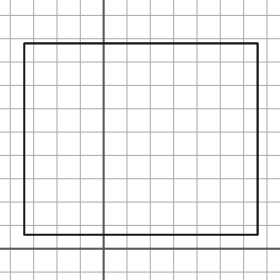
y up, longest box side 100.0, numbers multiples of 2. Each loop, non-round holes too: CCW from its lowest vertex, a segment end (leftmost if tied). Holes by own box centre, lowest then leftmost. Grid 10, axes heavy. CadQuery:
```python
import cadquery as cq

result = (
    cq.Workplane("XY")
    .moveTo(-34.0, 6.0)
    .lineTo(66.0, 6.0)
    .lineTo(66.0, 88.0)
    .lineTo(-34.0, 88.0)
    .close()
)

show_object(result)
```